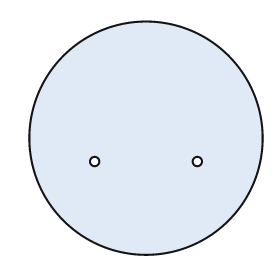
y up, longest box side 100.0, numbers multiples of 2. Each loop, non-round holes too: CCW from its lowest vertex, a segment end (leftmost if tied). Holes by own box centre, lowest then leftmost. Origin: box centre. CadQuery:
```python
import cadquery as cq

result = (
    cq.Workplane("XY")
    .moveTo(0.0, 0.0)
    .circle(50.0)
    .moveTo(-22.0, -10.0)
    .circle(2.0)
    .moveTo(22.0, -10.0)
    .circle(2.0)
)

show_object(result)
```